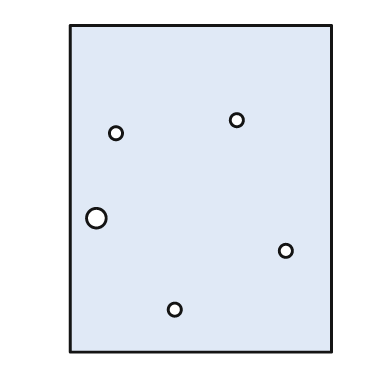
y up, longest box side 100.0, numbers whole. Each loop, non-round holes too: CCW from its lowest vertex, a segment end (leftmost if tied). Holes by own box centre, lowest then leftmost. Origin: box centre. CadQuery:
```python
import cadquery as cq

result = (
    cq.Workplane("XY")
    .moveTo(-40.0, -50.0)
    .lineTo(40.0, -50.0)
    .lineTo(40.0, 50.0)
    .lineTo(-40.0, 50.0)
    .close()
    .moveTo(-8.0, -37.0)
    .circle(2.0)
    .moveTo(26.0, -19.0)
    .circle(2.0)
    .moveTo(-32.0, -9.0)
    .circle(3.0)
    .moveTo(-26.0, 17.0)
    .circle(2.0)
    .moveTo(11.0, 21.0)
    .circle(2.0)
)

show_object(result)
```